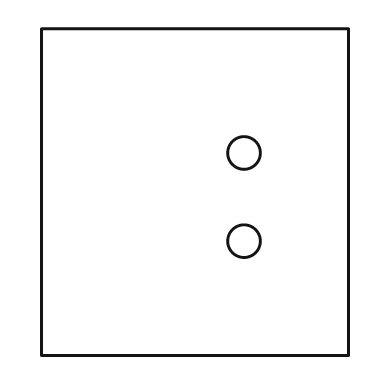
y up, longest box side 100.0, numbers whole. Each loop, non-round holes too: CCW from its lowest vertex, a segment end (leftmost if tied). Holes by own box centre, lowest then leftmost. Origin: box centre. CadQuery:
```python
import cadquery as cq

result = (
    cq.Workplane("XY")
    .moveTo(-47.0, -50.0)
    .lineTo(47.0, -50.0)
    .lineTo(47.0, 50.0)
    .lineTo(-47.0, 50.0)
    .close()
    .moveTo(15.0, -15.0)
    .circle(5.0)
    .moveTo(15.0, 12.0)
    .circle(5.0)
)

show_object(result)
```